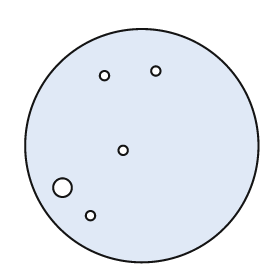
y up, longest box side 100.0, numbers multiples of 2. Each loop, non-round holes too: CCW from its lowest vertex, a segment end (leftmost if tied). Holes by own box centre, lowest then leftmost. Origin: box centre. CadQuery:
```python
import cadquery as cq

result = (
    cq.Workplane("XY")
    .moveTo(0.0, 0.0)
    .circle(50.0)
    .moveTo(-22.0, -30.0)
    .circle(2.0)
    .moveTo(-34.0, -18.0)
    .circle(4.0)
    .moveTo(-8.0, -2.0)
    .circle(2.0)
    .moveTo(-16.0, 30.0)
    .circle(2.0)
    .moveTo(6.0, 32.0)
    .circle(2.0)
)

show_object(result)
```